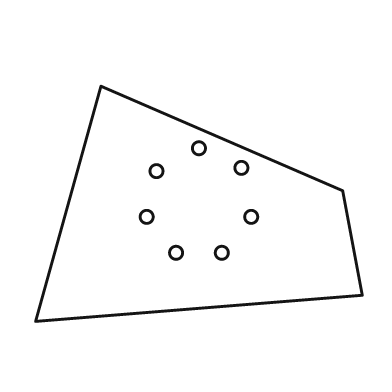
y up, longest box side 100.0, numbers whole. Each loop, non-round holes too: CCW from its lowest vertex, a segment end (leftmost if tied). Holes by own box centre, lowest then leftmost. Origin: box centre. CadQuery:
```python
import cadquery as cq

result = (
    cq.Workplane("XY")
    .moveTo(-50.0, -36.0)
    .lineTo(50.0, -28.0)
    .lineTo(44.0, 4.0)
    .lineTo(-30.0, 36.0)
    .close()
    .moveTo(-7.0, -15.0)
    .circle(2.0)
    .moveTo(7.0, -15.0)
    .circle(2.0)
    .moveTo(-16.0, -4.0)
    .circle(2.0)
    .moveTo(16.0, -4.0)
    .circle(2.0)
    .moveTo(-13.0, 10.0)
    .circle(2.0)
    .moveTo(13.0, 11.0)
    .circle(2.0)
    .moveTo(0.0, 17.0)
    .circle(2.0)
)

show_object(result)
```